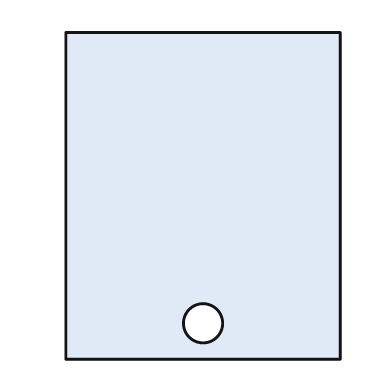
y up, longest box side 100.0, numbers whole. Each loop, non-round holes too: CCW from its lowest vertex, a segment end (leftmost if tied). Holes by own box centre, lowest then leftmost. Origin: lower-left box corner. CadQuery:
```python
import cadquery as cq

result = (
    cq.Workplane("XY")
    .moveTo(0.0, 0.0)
    .lineTo(84.0, 0.0)
    .lineTo(84.0, 100.0)
    .lineTo(0.0, 100.0)
    .close()
    .moveTo(42.0, 11.0)
    .circle(6.0)
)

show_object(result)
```